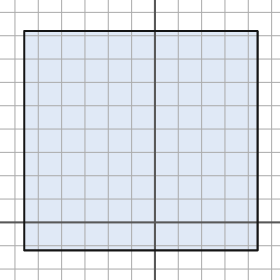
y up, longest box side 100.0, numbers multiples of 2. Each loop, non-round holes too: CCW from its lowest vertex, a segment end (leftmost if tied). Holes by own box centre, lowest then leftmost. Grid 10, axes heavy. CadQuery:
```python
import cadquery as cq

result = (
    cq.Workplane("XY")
    .moveTo(-56.0, -12.0)
    .lineTo(44.0, -12.0)
    .lineTo(44.0, 82.0)
    .lineTo(-56.0, 82.0)
    .close()
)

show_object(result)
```